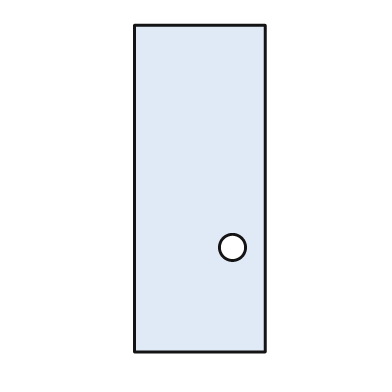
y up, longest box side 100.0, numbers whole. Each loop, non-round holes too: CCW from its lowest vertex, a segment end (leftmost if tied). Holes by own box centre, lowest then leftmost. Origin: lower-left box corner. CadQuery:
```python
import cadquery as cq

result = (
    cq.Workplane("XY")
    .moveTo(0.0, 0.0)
    .lineTo(40.0, 0.0)
    .lineTo(40.0, 100.0)
    .lineTo(0.0, 100.0)
    .close()
    .moveTo(30.0, 32.0)
    .circle(4.0)
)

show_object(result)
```